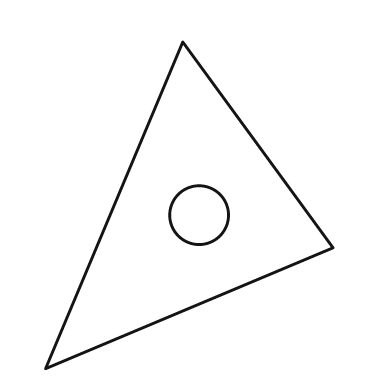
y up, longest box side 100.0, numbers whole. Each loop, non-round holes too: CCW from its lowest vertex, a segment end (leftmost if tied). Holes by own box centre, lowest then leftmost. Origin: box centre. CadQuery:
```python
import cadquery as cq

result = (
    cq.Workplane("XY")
    .moveTo(-44.0, -50.0)
    .lineTo(44.0, -13.0)
    .lineTo(-2.0, 50.0)
    .close()
    .moveTo(3.0, -3.0)
    .circle(9.0)
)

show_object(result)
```